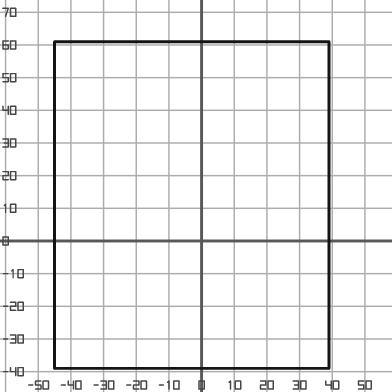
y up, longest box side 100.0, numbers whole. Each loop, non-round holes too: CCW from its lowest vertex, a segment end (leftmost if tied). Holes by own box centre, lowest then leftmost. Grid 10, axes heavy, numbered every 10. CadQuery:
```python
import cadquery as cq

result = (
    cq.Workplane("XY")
    .moveTo(-45.0, -39.0)
    .lineTo(39.0, -39.0)
    .lineTo(39.0, 61.0)
    .lineTo(-45.0, 61.0)
    .close()
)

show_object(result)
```